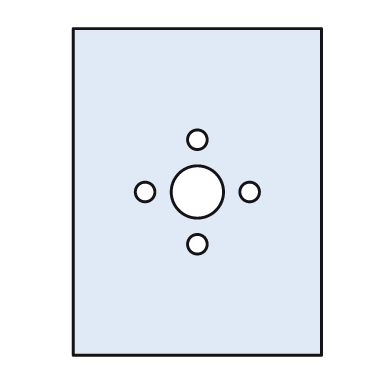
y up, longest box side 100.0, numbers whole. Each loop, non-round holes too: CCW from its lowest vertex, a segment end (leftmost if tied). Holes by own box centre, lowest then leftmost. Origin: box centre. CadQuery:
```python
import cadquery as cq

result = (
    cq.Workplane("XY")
    .moveTo(-38.0, -50.0)
    .lineTo(38.0, -50.0)
    .lineTo(38.0, 50.0)
    .lineTo(-38.0, 50.0)
    .close()
    .moveTo(0.0, -16.0)
    .circle(3.0)
    .moveTo(-16.0, 0.0)
    .circle(3.0)
    .moveTo(0.0, 0.0)
    .circle(8.0)
    .moveTo(16.0, 0.0)
    .circle(3.0)
    .moveTo(0.0, 16.0)
    .circle(3.0)
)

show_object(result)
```